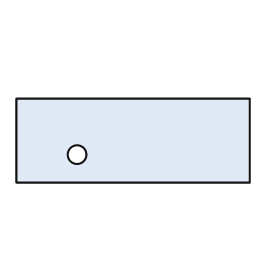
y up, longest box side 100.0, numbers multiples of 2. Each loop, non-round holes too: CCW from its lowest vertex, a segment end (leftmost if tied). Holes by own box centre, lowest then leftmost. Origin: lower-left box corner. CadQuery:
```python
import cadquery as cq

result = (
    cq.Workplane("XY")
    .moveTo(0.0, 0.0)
    .lineTo(100.0, 0.0)
    .lineTo(100.0, 36.0)
    .lineTo(0.0, 36.0)
    .close()
    .moveTo(26.0, 12.0)
    .circle(4.0)
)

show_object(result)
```